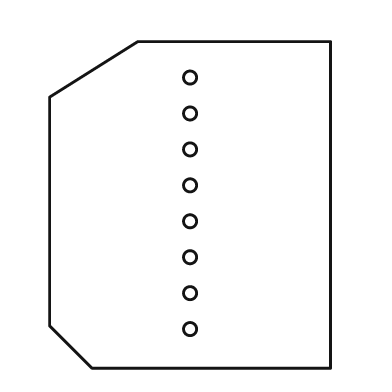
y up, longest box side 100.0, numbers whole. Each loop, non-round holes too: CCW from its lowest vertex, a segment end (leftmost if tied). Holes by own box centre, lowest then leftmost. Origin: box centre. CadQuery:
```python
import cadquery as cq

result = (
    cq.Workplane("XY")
    .moveTo(-30.0, -50.0)
    .lineTo(43.0, -50.0)
    .lineTo(43.0, 50.0)
    .lineTo(-16.0, 50.0)
    .lineTo(-43.0, 33.0)
    .lineTo(-43.0, -37.0)
    .close()
    .moveTo(0.0, -38.0)
    .circle(2.0)
    .moveTo(0.0, -27.0)
    .circle(2.0)
    .moveTo(0.0, -16.0)
    .circle(2.0)
    .moveTo(0.0, -5.0)
    .circle(2.0)
    .moveTo(0.0, 6.0)
    .circle(2.0)
    .moveTo(0.0, 17.0)
    .circle(2.0)
    .moveTo(0.0, 28.0)
    .circle(2.0)
    .moveTo(0.0, 39.0)
    .circle(2.0)
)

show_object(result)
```